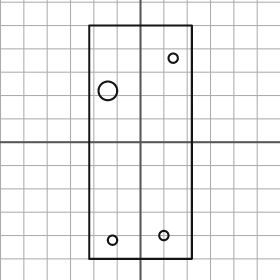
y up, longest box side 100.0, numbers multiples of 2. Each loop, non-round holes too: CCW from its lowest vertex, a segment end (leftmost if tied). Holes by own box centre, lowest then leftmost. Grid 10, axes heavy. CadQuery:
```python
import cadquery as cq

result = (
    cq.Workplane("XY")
    .moveTo(-22.0, -50.0)
    .lineTo(22.0, -50.0)
    .lineTo(22.0, 50.0)
    .lineTo(-22.0, 50.0)
    .close()
    .moveTo(-12.0, -42.0)
    .circle(2.0)
    .moveTo(10.0, -40.0)
    .circle(2.0)
    .moveTo(-14.0, 22.0)
    .circle(4.0)
    .moveTo(14.0, 36.0)
    .circle(2.0)
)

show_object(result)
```